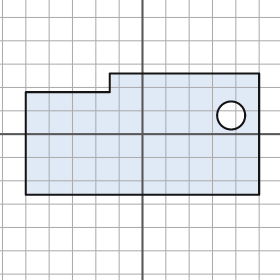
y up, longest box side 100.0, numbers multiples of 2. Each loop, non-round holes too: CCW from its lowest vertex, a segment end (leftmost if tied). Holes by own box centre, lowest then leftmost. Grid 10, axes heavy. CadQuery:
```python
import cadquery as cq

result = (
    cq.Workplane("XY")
    .moveTo(-50.0, -26.0)
    .lineTo(50.0, -26.0)
    .lineTo(50.0, 26.0)
    .lineTo(-14.0, 26.0)
    .lineTo(-14.0, 18.0)
    .lineTo(-50.0, 18.0)
    .close()
    .moveTo(38.0, 8.0)
    .circle(6.0)
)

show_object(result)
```